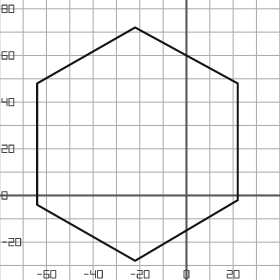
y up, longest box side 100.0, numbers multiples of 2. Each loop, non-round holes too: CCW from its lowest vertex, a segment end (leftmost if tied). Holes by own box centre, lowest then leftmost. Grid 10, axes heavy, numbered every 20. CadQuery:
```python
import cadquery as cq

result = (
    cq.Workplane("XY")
    .moveTo(-22.0, -28.0)
    .lineTo(22.0, -2.0)
    .lineTo(22.0, 48.0)
    .lineTo(-22.0, 72.0)
    .lineTo(-64.0, 48.0)
    .lineTo(-64.0, -4.0)
    .close()
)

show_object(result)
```